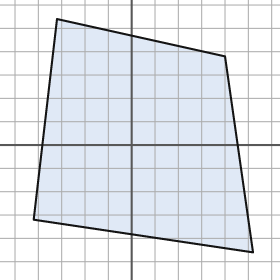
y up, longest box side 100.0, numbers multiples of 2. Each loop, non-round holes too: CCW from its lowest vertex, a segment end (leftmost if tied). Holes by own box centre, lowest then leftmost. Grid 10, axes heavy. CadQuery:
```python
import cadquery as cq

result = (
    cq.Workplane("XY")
    .moveTo(52.0, -46.0)
    .lineTo(40.0, 38.0)
    .lineTo(-32.0, 54.0)
    .lineTo(-42.0, -32.0)
    .close()
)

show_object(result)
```